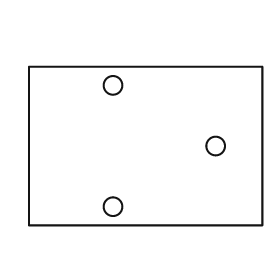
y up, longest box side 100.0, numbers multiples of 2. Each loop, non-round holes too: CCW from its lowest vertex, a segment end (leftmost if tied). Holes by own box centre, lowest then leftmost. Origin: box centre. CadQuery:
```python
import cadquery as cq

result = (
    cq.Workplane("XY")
    .moveTo(-50.0, -34.0)
    .lineTo(50.0, -34.0)
    .lineTo(50.0, 34.0)
    .lineTo(-50.0, 34.0)
    .close()
    .moveTo(-14.0, -26.0)
    .circle(4.0)
    .moveTo(30.0, 0.0)
    .circle(4.0)
    .moveTo(-14.0, 26.0)
    .circle(4.0)
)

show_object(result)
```